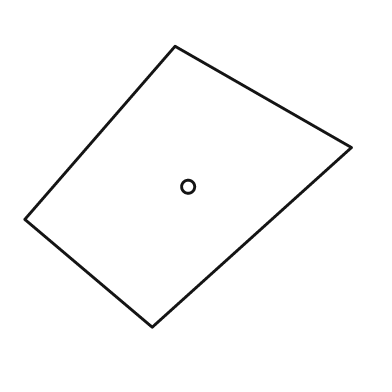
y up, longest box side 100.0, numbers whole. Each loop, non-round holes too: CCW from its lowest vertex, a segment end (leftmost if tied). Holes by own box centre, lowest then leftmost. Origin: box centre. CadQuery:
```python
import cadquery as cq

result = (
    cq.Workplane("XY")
    .moveTo(-11.0, -43.0)
    .lineTo(50.0, 12.0)
    .lineTo(-4.0, 43.0)
    .lineTo(-50.0, -10.0)
    .close()
    .moveTo(0.0, 0.0)
    .circle(2.0)
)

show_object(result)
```